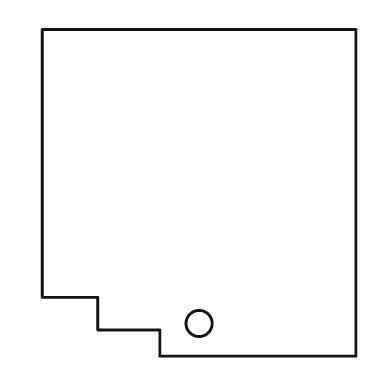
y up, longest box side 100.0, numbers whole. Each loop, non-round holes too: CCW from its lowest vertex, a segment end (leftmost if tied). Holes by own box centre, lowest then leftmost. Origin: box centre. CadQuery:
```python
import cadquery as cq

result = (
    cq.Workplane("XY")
    .moveTo(-12.0, -50.0)
    .lineTo(48.0, -50.0)
    .lineTo(48.0, 50.0)
    .lineTo(-48.0, 50.0)
    .lineTo(-48.0, -32.0)
    .lineTo(-31.0, -32.0)
    .lineTo(-31.0, -42.0)
    .lineTo(-12.0, -42.0)
    .close()
    .moveTo(0.0, -40.0)
    .circle(4.0)
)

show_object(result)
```